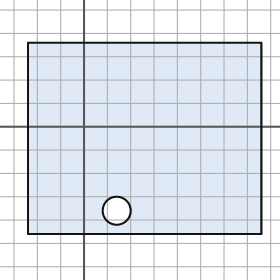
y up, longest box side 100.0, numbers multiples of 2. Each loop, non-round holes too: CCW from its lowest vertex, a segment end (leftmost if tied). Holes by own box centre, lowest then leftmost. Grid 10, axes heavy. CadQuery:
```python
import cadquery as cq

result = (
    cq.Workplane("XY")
    .moveTo(-24.0, -46.0)
    .lineTo(76.0, -46.0)
    .lineTo(76.0, 36.0)
    .lineTo(-24.0, 36.0)
    .close()
    .moveTo(14.0, -36.0)
    .circle(6.0)
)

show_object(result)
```